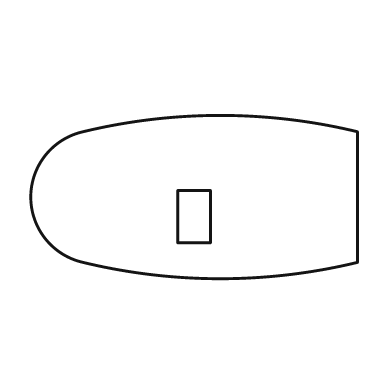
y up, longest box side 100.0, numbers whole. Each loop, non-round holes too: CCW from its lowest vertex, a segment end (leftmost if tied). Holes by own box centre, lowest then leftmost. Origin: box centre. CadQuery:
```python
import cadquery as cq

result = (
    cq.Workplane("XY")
    .moveTo(-34.0, -20.0)
    .threePointArc((8.0, -25.0), (50.0, -20.0))
    .lineTo(50.0, 20.0)
    .threePointArc((8.0, 25.0), (-34.0, 20.0))
    .threePointArc((-50.0, 0.0), (-34.0, -20.0))
    .close()
    .moveTo(-5.0, -14.0)
    .lineTo(5.0, -14.0)
    .lineTo(5.0, 2.0)
    .lineTo(-5.0, 2.0)
    .close()
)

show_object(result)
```